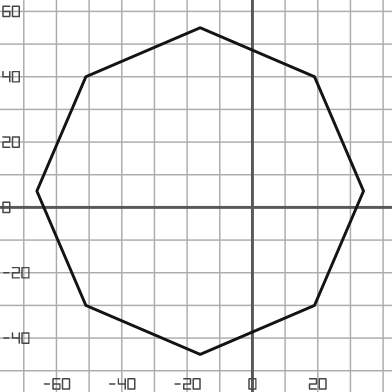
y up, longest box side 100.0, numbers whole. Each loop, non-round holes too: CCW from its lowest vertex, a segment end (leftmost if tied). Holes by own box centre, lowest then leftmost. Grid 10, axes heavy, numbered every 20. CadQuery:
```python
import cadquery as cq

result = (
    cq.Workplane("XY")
    .moveTo(-16.0, -45.0)
    .lineTo(19.0, -30.0)
    .lineTo(34.0, 5.0)
    .lineTo(19.0, 40.0)
    .lineTo(-16.0, 55.0)
    .lineTo(-51.0, 40.0)
    .lineTo(-66.0, 5.0)
    .lineTo(-51.0, -30.0)
    .close()
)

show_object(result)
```